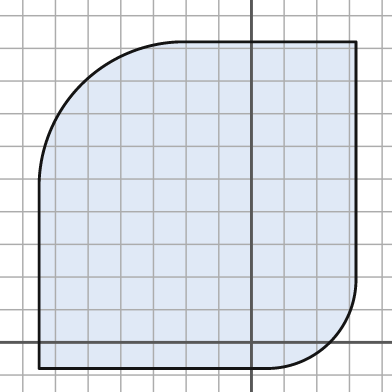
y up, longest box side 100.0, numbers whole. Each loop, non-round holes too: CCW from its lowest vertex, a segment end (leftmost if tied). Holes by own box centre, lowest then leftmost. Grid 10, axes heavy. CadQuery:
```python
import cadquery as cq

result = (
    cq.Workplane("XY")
    .moveTo(-65.0, -8.0)
    .lineTo(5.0, -8.0)
    .threePointArc((24.0, 0.0), (32.0, 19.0))
    .lineTo(32.0, 92.0)
    .lineTo(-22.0, 92.0)
    .threePointArc((-52.0, 79.0), (-65.0, 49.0))
    .close()
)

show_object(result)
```